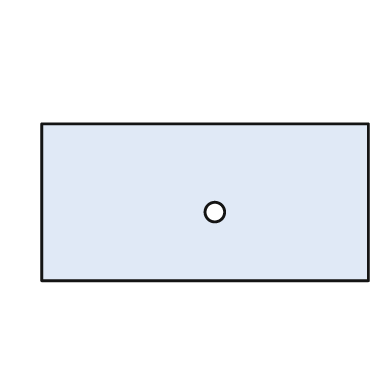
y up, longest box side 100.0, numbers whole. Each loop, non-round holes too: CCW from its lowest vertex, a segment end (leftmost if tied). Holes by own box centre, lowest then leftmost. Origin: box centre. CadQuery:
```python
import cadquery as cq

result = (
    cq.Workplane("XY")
    .moveTo(-50.0, -24.0)
    .lineTo(50.0, -24.0)
    .lineTo(50.0, 24.0)
    .lineTo(-50.0, 24.0)
    .close()
    .moveTo(3.0, -3.0)
    .circle(3.0)
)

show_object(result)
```